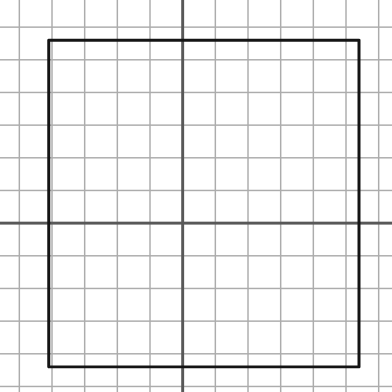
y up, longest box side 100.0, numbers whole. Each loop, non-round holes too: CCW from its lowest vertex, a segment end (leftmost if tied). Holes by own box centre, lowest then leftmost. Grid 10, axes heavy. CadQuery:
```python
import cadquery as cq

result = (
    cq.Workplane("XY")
    .moveTo(-41.0, -44.0)
    .lineTo(54.0, -44.0)
    .lineTo(54.0, 56.0)
    .lineTo(-41.0, 56.0)
    .close()
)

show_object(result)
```